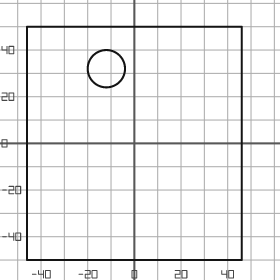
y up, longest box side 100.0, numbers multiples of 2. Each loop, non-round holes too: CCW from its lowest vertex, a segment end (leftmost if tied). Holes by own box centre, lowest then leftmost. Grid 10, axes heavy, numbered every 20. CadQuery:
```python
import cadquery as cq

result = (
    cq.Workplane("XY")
    .moveTo(-46.0, -50.0)
    .lineTo(46.0, -50.0)
    .lineTo(46.0, 50.0)
    .lineTo(-46.0, 50.0)
    .close()
    .moveTo(-12.0, 32.0)
    .circle(8.0)
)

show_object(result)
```